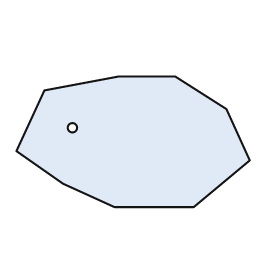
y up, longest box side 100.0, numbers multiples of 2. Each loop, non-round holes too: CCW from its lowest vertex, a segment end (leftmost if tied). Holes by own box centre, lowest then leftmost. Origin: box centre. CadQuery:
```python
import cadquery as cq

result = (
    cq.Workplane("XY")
    .moveTo(-8.0, -28.0)
    .lineTo(26.0, -28.0)
    .lineTo(50.0, -8.0)
    .lineTo(40.0, 14.0)
    .lineTo(18.0, 28.0)
    .lineTo(-6.0, 28.0)
    .lineTo(-38.0, 22.0)
    .lineTo(-50.0, -4.0)
    .lineTo(-30.0, -18.0)
    .close()
    .moveTo(-26.0, 6.0)
    .circle(2.0)
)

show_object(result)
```